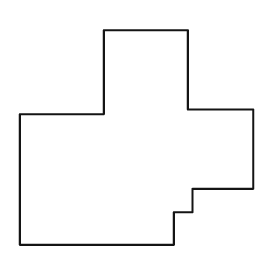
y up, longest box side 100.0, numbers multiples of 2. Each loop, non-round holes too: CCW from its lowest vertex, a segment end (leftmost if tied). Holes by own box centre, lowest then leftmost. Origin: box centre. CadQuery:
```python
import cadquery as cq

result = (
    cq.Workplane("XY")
    .moveTo(-50.0, -46.0)
    .lineTo(16.0, -46.0)
    .lineTo(16.0, -32.0)
    .lineTo(24.0, -32.0)
    .lineTo(24.0, -22.0)
    .lineTo(50.0, -22.0)
    .lineTo(50.0, 12.0)
    .lineTo(22.0, 12.0)
    .lineTo(22.0, 46.0)
    .lineTo(-14.0, 46.0)
    .lineTo(-14.0, 10.0)
    .lineTo(-50.0, 10.0)
    .close()
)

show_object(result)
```